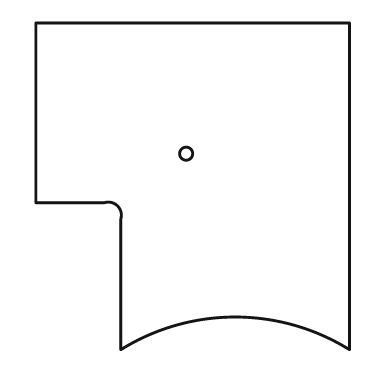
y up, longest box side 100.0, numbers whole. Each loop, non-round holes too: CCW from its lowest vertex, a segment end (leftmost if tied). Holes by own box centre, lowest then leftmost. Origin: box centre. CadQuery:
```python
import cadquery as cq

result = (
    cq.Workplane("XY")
    .moveTo(-22.0, -50.0)
    .threePointArc((13.0, -40.0), (48.0, -50.0))
    .lineTo(48.0, 50.0)
    .lineTo(-48.0, 50.0)
    .lineTo(-48.0, -5.0)
    .lineTo(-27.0, -5.0)
    .threePointArc((-23.0, -6.0), (-22.0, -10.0))
    .close()
    .moveTo(-2.0, 10.0)
    .circle(2.0)
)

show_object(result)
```